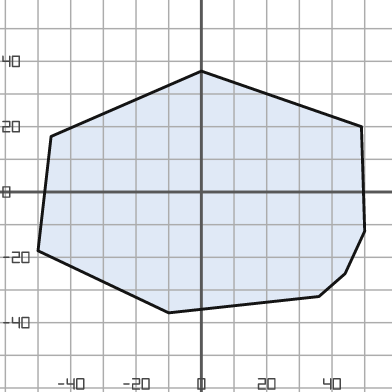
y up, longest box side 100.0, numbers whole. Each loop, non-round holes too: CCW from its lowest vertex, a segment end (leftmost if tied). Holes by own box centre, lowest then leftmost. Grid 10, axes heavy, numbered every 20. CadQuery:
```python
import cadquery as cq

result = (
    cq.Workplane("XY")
    .moveTo(-10.0, -37.0)
    .lineTo(36.0, -32.0)
    .lineTo(44.0, -25.0)
    .lineTo(50.0, -12.0)
    .lineTo(49.0, 20.0)
    .lineTo(0.0, 37.0)
    .lineTo(-46.0, 17.0)
    .lineTo(-50.0, -18.0)
    .close()
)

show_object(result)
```